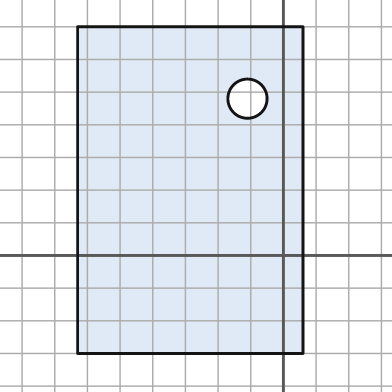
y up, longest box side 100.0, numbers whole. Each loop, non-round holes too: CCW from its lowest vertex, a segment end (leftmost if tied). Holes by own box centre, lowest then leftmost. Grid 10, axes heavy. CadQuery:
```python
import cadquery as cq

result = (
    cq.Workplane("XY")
    .moveTo(-63.0, -30.0)
    .lineTo(6.0, -30.0)
    .lineTo(6.0, 70.0)
    .lineTo(-63.0, 70.0)
    .close()
    .moveTo(-11.0, 48.0)
    .circle(6.0)
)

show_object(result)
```